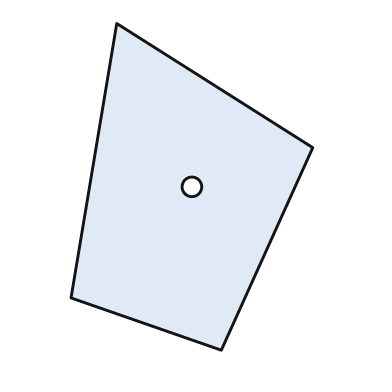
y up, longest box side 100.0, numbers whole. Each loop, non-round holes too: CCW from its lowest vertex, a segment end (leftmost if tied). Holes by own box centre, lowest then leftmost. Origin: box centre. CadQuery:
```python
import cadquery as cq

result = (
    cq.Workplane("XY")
    .moveTo(9.0, -50.0)
    .lineTo(37.0, 12.0)
    .lineTo(-23.0, 50.0)
    .lineTo(-37.0, -34.0)
    .close()
    .moveTo(0.0, 0.0)
    .circle(3.0)
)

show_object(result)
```